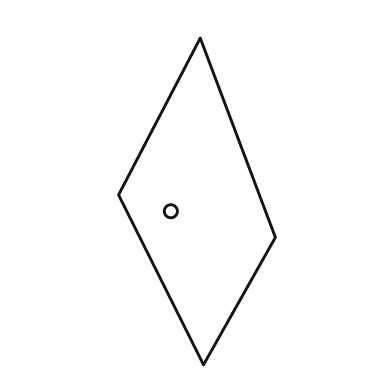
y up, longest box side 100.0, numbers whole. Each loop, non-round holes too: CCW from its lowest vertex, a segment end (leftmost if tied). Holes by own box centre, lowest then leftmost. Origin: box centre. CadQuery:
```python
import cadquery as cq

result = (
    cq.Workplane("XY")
    .moveTo(2.0, -50.0)
    .lineTo(24.0, -11.0)
    .lineTo(1.0, 50.0)
    .lineTo(-24.0, 2.0)
    .close()
    .moveTo(-8.0, -3.0)
    .circle(2.0)
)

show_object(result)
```